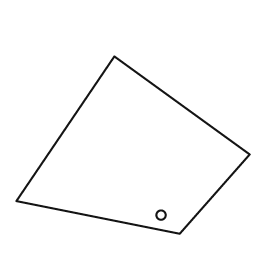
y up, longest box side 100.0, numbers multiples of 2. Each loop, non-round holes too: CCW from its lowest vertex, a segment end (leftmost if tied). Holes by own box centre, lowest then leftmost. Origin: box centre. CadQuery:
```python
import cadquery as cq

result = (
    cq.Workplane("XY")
    .moveTo(20.0, -38.0)
    .lineTo(50.0, -4.0)
    .lineTo(-8.0, 38.0)
    .lineTo(-50.0, -24.0)
    .close()
    .moveTo(12.0, -30.0)
    .circle(2.0)
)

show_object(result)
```